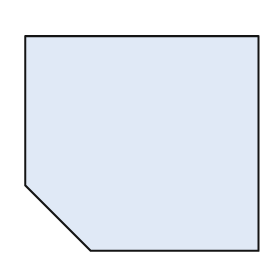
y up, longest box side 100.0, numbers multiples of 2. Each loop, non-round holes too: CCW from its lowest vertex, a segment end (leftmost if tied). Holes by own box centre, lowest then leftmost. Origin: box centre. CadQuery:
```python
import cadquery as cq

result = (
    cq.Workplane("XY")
    .moveTo(-22.0, -46.0)
    .lineTo(50.0, -46.0)
    .lineTo(50.0, 46.0)
    .lineTo(-50.0, 46.0)
    .lineTo(-50.0, -18.0)
    .close()
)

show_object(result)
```